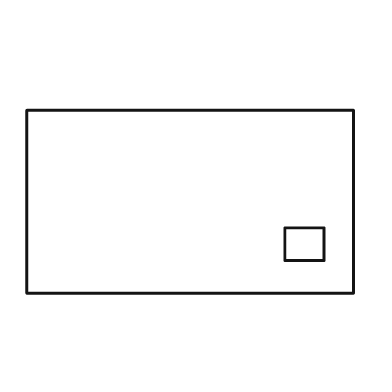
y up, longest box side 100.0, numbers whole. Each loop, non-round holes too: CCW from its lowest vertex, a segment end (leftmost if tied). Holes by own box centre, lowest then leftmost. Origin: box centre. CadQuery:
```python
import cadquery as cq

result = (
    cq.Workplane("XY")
    .moveTo(-50.0, -28.0)
    .lineTo(50.0, -28.0)
    .lineTo(50.0, 28.0)
    .lineTo(-50.0, 28.0)
    .close()
    .moveTo(29.0, -18.0)
    .lineTo(41.0, -18.0)
    .lineTo(41.0, -8.0)
    .lineTo(29.0, -8.0)
    .close()
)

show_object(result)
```